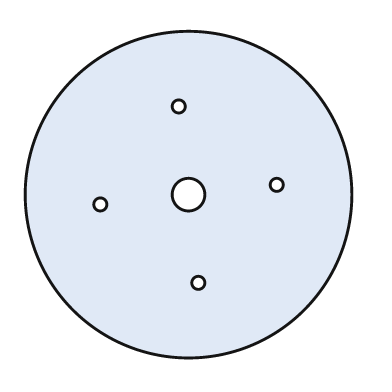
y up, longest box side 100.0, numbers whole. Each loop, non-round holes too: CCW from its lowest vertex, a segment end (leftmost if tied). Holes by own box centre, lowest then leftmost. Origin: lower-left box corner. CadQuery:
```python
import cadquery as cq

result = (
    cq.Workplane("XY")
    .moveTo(50.0, 50.0)
    .circle(50.0)
    .moveTo(53.0, 23.0)
    .circle(2.0)
    .moveTo(23.0, 47.0)
    .circle(2.0)
    .moveTo(50.0, 50.0)
    .circle(5.0)
    .moveTo(77.0, 53.0)
    .circle(2.0)
    .moveTo(47.0, 77.0)
    .circle(2.0)
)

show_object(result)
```